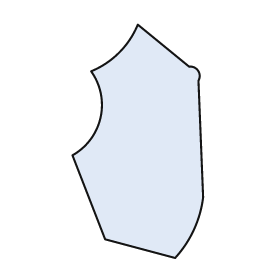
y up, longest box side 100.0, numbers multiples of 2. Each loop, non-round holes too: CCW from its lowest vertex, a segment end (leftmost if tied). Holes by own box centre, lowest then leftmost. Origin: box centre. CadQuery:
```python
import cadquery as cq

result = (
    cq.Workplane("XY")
    .moveTo(16.0, -50.0)
    .threePointArc((24.0, -38.0), (28.0, -24.0))
    .lineTo(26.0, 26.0)
    .threePointArc((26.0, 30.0), (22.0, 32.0))
    .lineTo(0.0, 50.0)
    .threePointArc((-8.0, 38.0), (-20.0, 30.0))
    .threePointArc((-16.0, 10.0), (-28.0, -6.0))
    .lineTo(-14.0, -42.0)
    .close()
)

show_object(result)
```